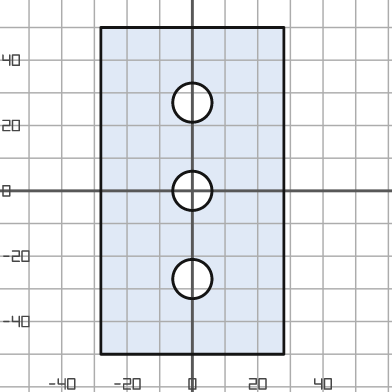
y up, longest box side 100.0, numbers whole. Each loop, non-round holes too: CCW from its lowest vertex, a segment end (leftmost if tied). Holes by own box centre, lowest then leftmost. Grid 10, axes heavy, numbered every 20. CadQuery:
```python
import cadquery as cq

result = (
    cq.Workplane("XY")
    .moveTo(-28.0, -50.0)
    .lineTo(28.0, -50.0)
    .lineTo(28.0, 50.0)
    .lineTo(-28.0, 50.0)
    .close()
    .moveTo(0.0, -27.0)
    .circle(6.0)
    .moveTo(0.0, 0.0)
    .circle(6.0)
    .moveTo(0.0, 27.0)
    .circle(6.0)
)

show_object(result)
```